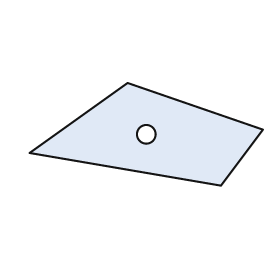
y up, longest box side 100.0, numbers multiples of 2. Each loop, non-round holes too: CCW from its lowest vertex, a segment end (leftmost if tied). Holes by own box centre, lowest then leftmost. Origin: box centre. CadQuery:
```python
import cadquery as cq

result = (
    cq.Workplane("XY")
    .moveTo(32.0, -22.0)
    .lineTo(50.0, 2.0)
    .lineTo(-8.0, 22.0)
    .lineTo(-50.0, -8.0)
    .close()
    .moveTo(0.0, 0.0)
    .circle(4.0)
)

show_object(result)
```